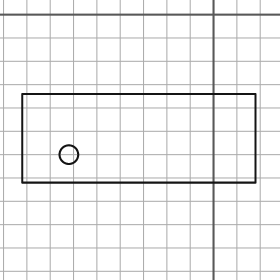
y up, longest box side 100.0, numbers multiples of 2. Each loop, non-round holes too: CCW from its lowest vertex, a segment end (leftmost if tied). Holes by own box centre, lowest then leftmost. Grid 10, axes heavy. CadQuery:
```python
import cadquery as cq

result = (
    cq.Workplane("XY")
    .moveTo(-82.0, -72.0)
    .lineTo(18.0, -72.0)
    .lineTo(18.0, -34.0)
    .lineTo(-82.0, -34.0)
    .close()
    .moveTo(-62.0, -60.0)
    .circle(4.0)
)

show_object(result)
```